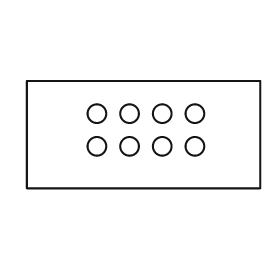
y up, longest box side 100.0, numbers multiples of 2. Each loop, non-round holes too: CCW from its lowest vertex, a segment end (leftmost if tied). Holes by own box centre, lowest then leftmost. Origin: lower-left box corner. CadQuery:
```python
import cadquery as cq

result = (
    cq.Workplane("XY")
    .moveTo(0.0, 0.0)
    .lineTo(100.0, 0.0)
    .lineTo(100.0, 46.0)
    .lineTo(0.0, 46.0)
    .close()
    .moveTo(30.0, 18.0)
    .circle(4.0)
    .moveTo(44.0, 18.0)
    .circle(4.0)
    .moveTo(58.0, 18.0)
    .circle(4.0)
    .moveTo(72.0, 18.0)
    .circle(4.0)
    .moveTo(30.0, 32.0)
    .circle(4.0)
    .moveTo(44.0, 32.0)
    .circle(4.0)
    .moveTo(58.0, 32.0)
    .circle(4.0)
    .moveTo(72.0, 32.0)
    .circle(4.0)
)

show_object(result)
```